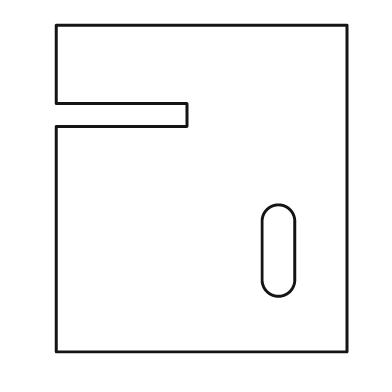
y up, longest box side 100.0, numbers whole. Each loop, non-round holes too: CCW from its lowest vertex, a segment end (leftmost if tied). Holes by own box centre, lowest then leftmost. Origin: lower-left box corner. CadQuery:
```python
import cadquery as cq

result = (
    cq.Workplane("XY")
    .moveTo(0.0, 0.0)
    .lineTo(89.0, 0.0)
    .lineTo(89.0, 100.0)
    .lineTo(0.0, 100.0)
    .lineTo(0.0, 76.0)
    .lineTo(40.0, 76.0)
    .lineTo(40.0, 69.0)
    .lineTo(0.0, 69.0)
    .close()
    .moveTo(63.0, 22.0)
    .threePointArc((68.0, 17.0), (73.0, 22.0))
    .lineTo(73.0, 40.0)
    .threePointArc((68.0, 45.0), (63.0, 40.0))
    .close()
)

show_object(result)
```